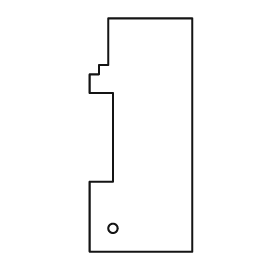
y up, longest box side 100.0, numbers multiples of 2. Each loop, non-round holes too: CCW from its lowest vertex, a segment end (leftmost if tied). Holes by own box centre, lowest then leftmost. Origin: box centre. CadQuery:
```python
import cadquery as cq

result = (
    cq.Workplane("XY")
    .moveTo(-22.0, -50.0)
    .lineTo(22.0, -50.0)
    .lineTo(22.0, 50.0)
    .lineTo(-14.0, 50.0)
    .lineTo(-14.0, 30.0)
    .lineTo(-18.0, 30.0)
    .lineTo(-18.0, 26.0)
    .lineTo(-22.0, 26.0)
    .lineTo(-22.0, 18.0)
    .lineTo(-12.0, 18.0)
    .lineTo(-12.0, -20.0)
    .lineTo(-22.0, -20.0)
    .close()
    .moveTo(-12.0, -40.0)
    .circle(2.0)
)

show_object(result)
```